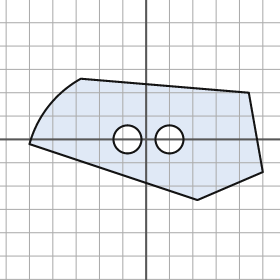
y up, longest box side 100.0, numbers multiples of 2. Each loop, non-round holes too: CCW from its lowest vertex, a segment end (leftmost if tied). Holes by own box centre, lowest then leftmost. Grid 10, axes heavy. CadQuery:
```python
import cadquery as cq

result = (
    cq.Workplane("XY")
    .moveTo(22.0, -26.0)
    .lineTo(50.0, -14.0)
    .lineTo(44.0, 20.0)
    .lineTo(-28.0, 26.0)
    .threePointArc((-42.0, 14.0), (-50.0, -2.0))
    .close()
    .moveTo(-8.0, 0.0)
    .circle(6.0)
    .moveTo(10.0, 0.0)
    .circle(6.0)
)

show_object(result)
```